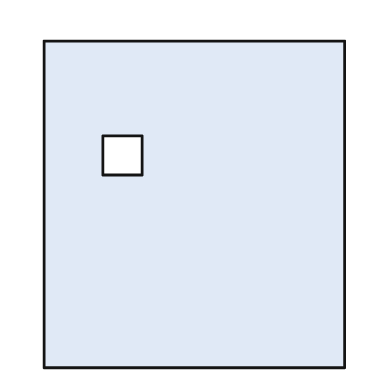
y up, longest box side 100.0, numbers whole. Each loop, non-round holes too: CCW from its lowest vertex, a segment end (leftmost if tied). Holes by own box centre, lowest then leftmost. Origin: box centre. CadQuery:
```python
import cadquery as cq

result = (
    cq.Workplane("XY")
    .moveTo(-46.0, -50.0)
    .lineTo(46.0, -50.0)
    .lineTo(46.0, 50.0)
    .lineTo(-46.0, 50.0)
    .close()
    .moveTo(-28.0, 9.0)
    .lineTo(-16.0, 9.0)
    .lineTo(-16.0, 21.0)
    .lineTo(-28.0, 21.0)
    .close()
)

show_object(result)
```